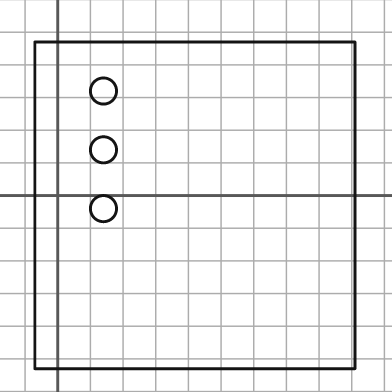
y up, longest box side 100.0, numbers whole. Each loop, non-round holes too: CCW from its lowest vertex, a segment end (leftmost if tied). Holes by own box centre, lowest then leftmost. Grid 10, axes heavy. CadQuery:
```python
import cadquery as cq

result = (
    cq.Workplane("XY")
    .moveTo(-7.0, -53.0)
    .lineTo(91.0, -53.0)
    .lineTo(91.0, 47.0)
    .lineTo(-7.0, 47.0)
    .close()
    .moveTo(14.0, -4.0)
    .circle(4.0)
    .moveTo(14.0, 14.0)
    .circle(4.0)
    .moveTo(14.0, 32.0)
    .circle(4.0)
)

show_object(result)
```